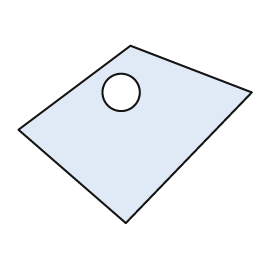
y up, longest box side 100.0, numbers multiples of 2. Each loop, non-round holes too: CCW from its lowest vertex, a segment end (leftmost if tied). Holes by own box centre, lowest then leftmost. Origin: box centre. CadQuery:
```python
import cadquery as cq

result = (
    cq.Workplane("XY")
    .moveTo(-4.0, -38.0)
    .lineTo(50.0, 18.0)
    .lineTo(-2.0, 38.0)
    .lineTo(-50.0, 2.0)
    .close()
    .moveTo(-6.0, 18.0)
    .circle(8.0)
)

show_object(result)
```